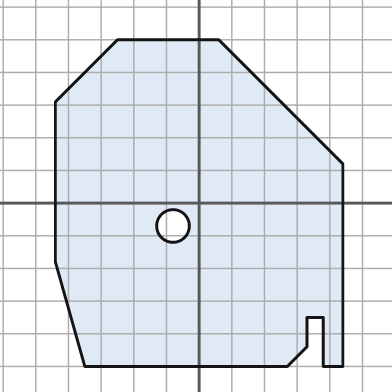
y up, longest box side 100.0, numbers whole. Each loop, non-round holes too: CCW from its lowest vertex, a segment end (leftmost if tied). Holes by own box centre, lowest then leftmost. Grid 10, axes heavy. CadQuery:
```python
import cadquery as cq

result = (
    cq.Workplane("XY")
    .moveTo(-35.0, -50.0)
    .lineTo(27.0, -50.0)
    .lineTo(33.0, -44.0)
    .lineTo(33.0, -35.0)
    .lineTo(38.0, -35.0)
    .lineTo(38.0, -50.0)
    .lineTo(44.0, -50.0)
    .lineTo(44.0, 12.0)
    .lineTo(6.0, 50.0)
    .lineTo(-25.0, 50.0)
    .lineTo(-44.0, 31.0)
    .lineTo(-44.0, -18.0)
    .close()
    .moveTo(-8.0, -7.0)
    .circle(5.0)
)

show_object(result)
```